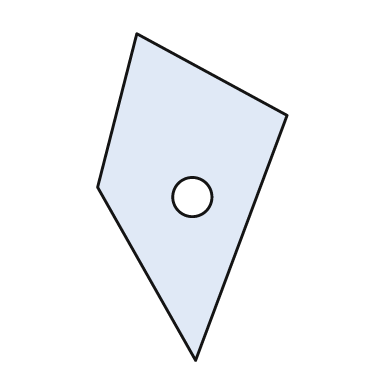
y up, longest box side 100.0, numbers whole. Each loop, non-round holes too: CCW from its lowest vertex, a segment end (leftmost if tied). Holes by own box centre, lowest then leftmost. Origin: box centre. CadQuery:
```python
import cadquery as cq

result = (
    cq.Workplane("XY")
    .moveTo(1.0, -50.0)
    .lineTo(29.0, 25.0)
    .lineTo(-17.0, 50.0)
    .lineTo(-29.0, 3.0)
    .close()
    .moveTo(0.0, 0.0)
    .circle(6.0)
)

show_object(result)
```